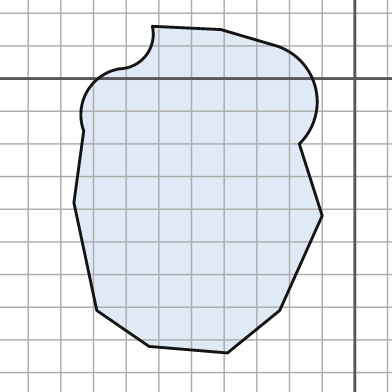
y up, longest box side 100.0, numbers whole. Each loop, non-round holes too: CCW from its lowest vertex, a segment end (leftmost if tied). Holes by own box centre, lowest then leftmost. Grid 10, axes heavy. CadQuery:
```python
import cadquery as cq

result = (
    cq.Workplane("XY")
    .moveTo(-39.0, -84.0)
    .lineTo(-23.0, -71.0)
    .lineTo(-10.0, -42.0)
    .lineTo(-17.0, -20.0)
    .threePointArc((-12.0, -3.0), (-24.0, 10.0))
    .lineTo(-41.0, 15.0)
    .lineTo(-62.0, 16.0)
    .threePointArc((-64.0, 7.0), (-72.0, 3.0))
    .threePointArc((-82.0, -4.0), (-83.0, -16.0))
    .lineTo(-86.0, -38.0)
    .lineTo(-79.0, -71.0)
    .lineTo(-63.0, -82.0)
    .close()
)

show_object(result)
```